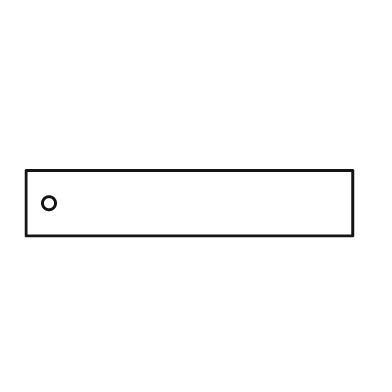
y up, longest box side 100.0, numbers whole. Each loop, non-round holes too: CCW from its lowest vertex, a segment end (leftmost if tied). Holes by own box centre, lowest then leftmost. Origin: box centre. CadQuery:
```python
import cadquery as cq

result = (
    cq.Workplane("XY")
    .moveTo(-50.0, -10.0)
    .lineTo(50.0, -10.0)
    .lineTo(50.0, 10.0)
    .lineTo(-50.0, 10.0)
    .close()
    .moveTo(-43.0, 0.0)
    .circle(2.0)
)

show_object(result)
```